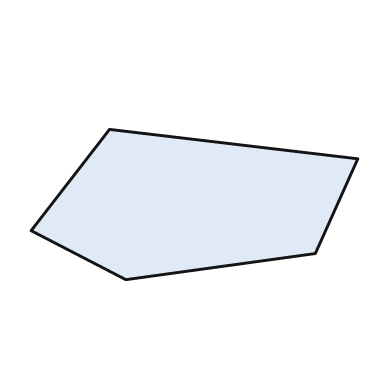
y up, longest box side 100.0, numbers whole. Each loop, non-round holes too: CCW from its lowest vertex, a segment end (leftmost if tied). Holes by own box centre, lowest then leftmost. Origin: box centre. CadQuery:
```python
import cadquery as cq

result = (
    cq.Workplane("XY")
    .moveTo(-21.0, -23.0)
    .lineTo(37.0, -15.0)
    .lineTo(50.0, 14.0)
    .lineTo(-26.0, 23.0)
    .lineTo(-50.0, -8.0)
    .close()
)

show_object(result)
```